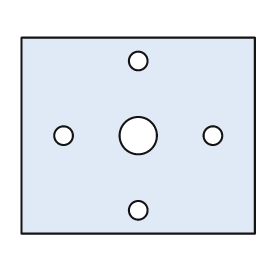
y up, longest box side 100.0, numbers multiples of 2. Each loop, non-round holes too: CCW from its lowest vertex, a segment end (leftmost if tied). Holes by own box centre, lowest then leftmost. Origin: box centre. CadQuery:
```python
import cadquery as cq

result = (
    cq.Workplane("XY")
    .moveTo(-50.0, -42.0)
    .lineTo(50.0, -42.0)
    .lineTo(50.0, 42.0)
    .lineTo(-50.0, 42.0)
    .close()
    .moveTo(0.0, -32.0)
    .circle(4.0)
    .moveTo(-32.0, 0.0)
    .circle(4.0)
    .moveTo(0.0, 0.0)
    .circle(8.0)
    .moveTo(32.0, 0.0)
    .circle(4.0)
    .moveTo(0.0, 32.0)
    .circle(4.0)
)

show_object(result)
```